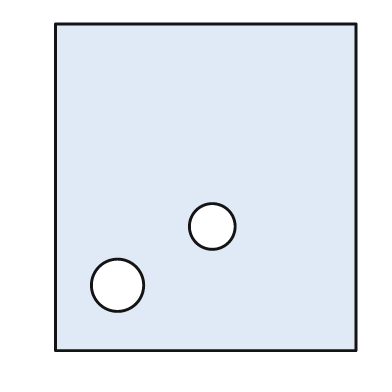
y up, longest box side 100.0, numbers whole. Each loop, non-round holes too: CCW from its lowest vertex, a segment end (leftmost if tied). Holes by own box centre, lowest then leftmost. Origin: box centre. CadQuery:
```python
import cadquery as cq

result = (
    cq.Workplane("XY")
    .moveTo(-46.0, -50.0)
    .lineTo(46.0, -50.0)
    .lineTo(46.0, 50.0)
    .lineTo(-46.0, 50.0)
    .close()
    .moveTo(-27.0, -30.0)
    .circle(8.0)
    .moveTo(2.0, -12.0)
    .circle(7.0)
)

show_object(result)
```